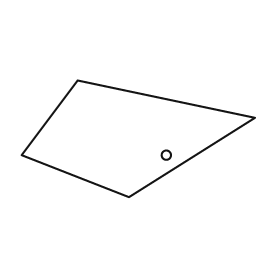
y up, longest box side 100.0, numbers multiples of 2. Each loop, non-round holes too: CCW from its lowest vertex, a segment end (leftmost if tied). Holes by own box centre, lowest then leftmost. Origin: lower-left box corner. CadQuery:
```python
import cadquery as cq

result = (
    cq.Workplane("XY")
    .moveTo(46.0, 0.0)
    .lineTo(100.0, 34.0)
    .lineTo(24.0, 50.0)
    .lineTo(0.0, 18.0)
    .close()
    .moveTo(62.0, 18.0)
    .circle(2.0)
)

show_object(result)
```